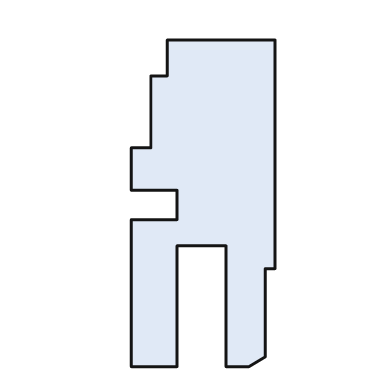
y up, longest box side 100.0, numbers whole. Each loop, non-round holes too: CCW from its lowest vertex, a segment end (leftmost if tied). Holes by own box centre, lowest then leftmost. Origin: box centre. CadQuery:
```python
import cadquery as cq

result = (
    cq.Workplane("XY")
    .moveTo(-22.0, -50.0)
    .lineTo(-8.0, -50.0)
    .lineTo(-8.0, -13.0)
    .lineTo(7.0, -13.0)
    .lineTo(7.0, -50.0)
    .lineTo(14.0, -50.0)
    .lineTo(19.0, -47.0)
    .lineTo(19.0, -20.0)
    .lineTo(22.0, -20.0)
    .lineTo(22.0, 50.0)
    .lineTo(-11.0, 50.0)
    .lineTo(-11.0, 39.0)
    .lineTo(-16.0, 39.0)
    .lineTo(-16.0, 17.0)
    .lineTo(-22.0, 17.0)
    .lineTo(-22.0, 4.0)
    .lineTo(-8.0, 4.0)
    .lineTo(-8.0, -5.0)
    .lineTo(-22.0, -5.0)
    .close()
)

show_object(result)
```